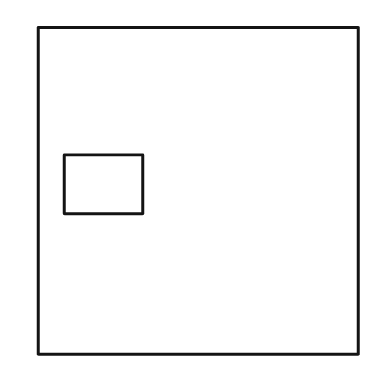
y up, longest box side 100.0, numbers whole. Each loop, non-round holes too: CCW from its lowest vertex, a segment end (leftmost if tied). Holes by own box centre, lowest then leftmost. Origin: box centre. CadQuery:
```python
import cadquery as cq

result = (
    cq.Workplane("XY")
    .moveTo(-49.0, -50.0)
    .lineTo(49.0, -50.0)
    .lineTo(49.0, 50.0)
    .lineTo(-49.0, 50.0)
    .close()
    .moveTo(-41.0, -7.0)
    .lineTo(-17.0, -7.0)
    .lineTo(-17.0, 11.0)
    .lineTo(-41.0, 11.0)
    .close()
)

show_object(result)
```